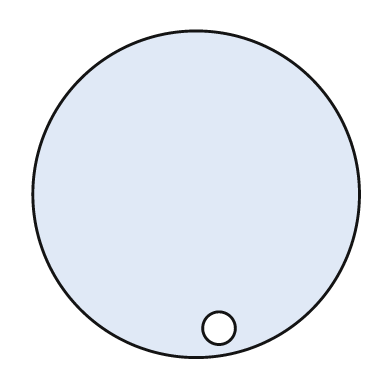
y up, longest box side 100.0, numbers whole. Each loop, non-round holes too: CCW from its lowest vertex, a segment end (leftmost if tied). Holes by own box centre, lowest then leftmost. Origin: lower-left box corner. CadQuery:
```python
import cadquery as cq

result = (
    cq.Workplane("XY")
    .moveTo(50.0, 50.0)
    .circle(50.0)
    .moveTo(57.0, 9.0)
    .circle(5.0)
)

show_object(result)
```